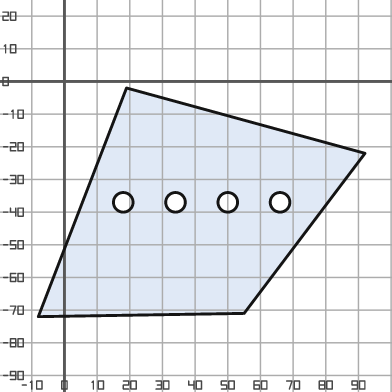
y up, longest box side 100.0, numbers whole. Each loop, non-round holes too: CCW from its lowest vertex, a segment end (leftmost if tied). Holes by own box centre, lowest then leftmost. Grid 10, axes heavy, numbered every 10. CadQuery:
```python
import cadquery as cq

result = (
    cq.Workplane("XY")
    .moveTo(-8.0, -72.0)
    .lineTo(55.0, -71.0)
    .lineTo(92.0, -22.0)
    .lineTo(19.0, -2.0)
    .close()
    .moveTo(18.0, -37.0)
    .circle(3.0)
    .moveTo(34.0, -37.0)
    .circle(3.0)
    .moveTo(50.0, -37.0)
    .circle(3.0)
    .moveTo(66.0, -37.0)
    .circle(3.0)
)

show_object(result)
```